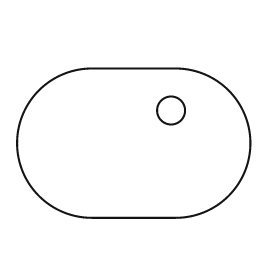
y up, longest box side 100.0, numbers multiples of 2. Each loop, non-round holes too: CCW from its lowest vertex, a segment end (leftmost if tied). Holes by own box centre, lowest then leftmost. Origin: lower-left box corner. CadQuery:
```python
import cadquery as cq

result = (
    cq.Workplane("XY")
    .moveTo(32.0, 0.0)
    .lineTo(68.0, 0.0)
    .threePointArc((100.0, 32.0), (68.0, 64.0))
    .lineTo(32.0, 64.0)
    .threePointArc((0.0, 32.0), (32.0, 0.0))
    .close()
    .moveTo(66.0, 46.0)
    .circle(6.0)
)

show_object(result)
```